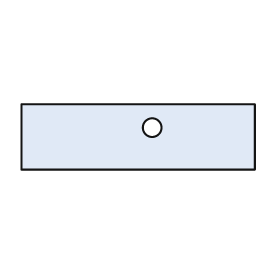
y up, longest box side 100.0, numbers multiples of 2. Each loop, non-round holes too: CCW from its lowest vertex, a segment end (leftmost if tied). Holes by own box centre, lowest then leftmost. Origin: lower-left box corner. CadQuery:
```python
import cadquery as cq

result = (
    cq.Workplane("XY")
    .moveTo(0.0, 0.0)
    .lineTo(100.0, 0.0)
    .lineTo(100.0, 28.0)
    .lineTo(0.0, 28.0)
    .close()
    .moveTo(56.0, 18.0)
    .circle(4.0)
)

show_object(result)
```